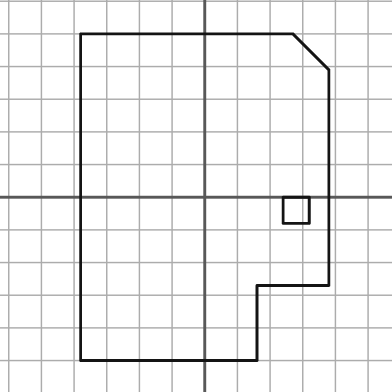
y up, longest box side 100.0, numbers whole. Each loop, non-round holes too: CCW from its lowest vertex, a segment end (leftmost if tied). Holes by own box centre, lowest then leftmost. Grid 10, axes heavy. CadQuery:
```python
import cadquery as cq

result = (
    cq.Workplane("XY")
    .moveTo(-38.0, -50.0)
    .lineTo(16.0, -50.0)
    .lineTo(16.0, -27.0)
    .lineTo(38.0, -27.0)
    .lineTo(38.0, 39.0)
    .lineTo(27.0, 50.0)
    .lineTo(-38.0, 50.0)
    .close()
    .moveTo(24.0, -8.0)
    .lineTo(32.0, -8.0)
    .lineTo(32.0, 0.0)
    .lineTo(24.0, 0.0)
    .close()
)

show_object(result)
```